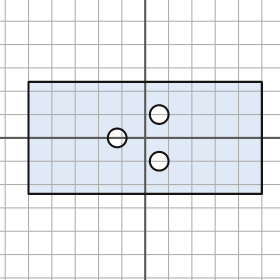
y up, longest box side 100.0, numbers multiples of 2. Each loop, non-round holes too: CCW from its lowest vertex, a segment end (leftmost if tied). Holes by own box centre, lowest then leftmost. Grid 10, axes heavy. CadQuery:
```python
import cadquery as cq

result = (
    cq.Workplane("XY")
    .moveTo(-50.0, -24.0)
    .lineTo(50.0, -24.0)
    .lineTo(50.0, 24.0)
    .lineTo(-50.0, 24.0)
    .close()
    .moveTo(6.0, -10.0)
    .circle(4.0)
    .moveTo(-12.0, 0.0)
    .circle(4.0)
    .moveTo(6.0, 10.0)
    .circle(4.0)
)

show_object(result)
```